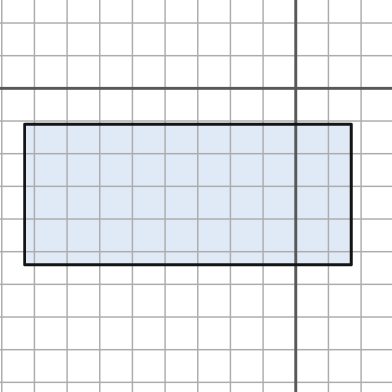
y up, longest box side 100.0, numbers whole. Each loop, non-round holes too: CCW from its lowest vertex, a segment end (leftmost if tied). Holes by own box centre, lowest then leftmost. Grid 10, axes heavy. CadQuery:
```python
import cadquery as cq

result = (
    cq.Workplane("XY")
    .moveTo(-83.0, -54.0)
    .lineTo(17.0, -54.0)
    .lineTo(17.0, -11.0)
    .lineTo(-83.0, -11.0)
    .close()
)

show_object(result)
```